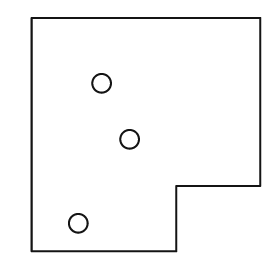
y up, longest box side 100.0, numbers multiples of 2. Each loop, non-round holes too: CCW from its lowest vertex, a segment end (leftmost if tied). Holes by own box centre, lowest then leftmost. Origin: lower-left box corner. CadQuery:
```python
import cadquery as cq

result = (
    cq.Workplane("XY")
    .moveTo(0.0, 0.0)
    .lineTo(62.0, 0.0)
    .lineTo(62.0, 28.0)
    .lineTo(98.0, 28.0)
    .lineTo(98.0, 100.0)
    .lineTo(0.0, 100.0)
    .close()
    .moveTo(20.0, 12.0)
    .circle(4.0)
    .moveTo(42.0, 48.0)
    .circle(4.0)
    .moveTo(30.0, 72.0)
    .circle(4.0)
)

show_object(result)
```